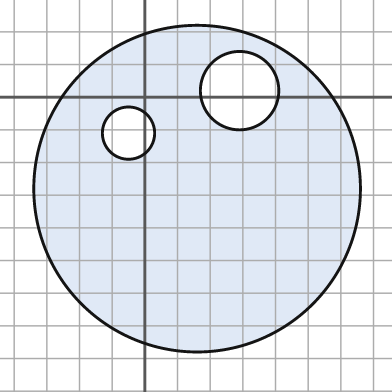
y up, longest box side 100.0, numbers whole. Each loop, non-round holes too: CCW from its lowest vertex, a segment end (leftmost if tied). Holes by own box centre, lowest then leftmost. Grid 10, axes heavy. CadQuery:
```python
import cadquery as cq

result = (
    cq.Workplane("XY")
    .moveTo(16.0, -28.0)
    .circle(50.0)
    .moveTo(-5.0, -11.0)
    .circle(8.0)
    .moveTo(29.0, 2.0)
    .circle(12.0)
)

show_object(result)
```